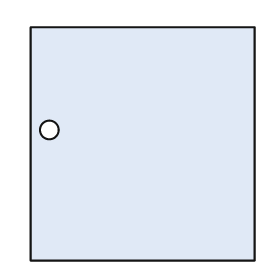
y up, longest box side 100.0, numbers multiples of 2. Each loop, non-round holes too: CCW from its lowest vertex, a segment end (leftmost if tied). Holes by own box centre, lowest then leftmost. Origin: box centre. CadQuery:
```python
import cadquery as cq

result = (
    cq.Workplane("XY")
    .moveTo(-48.0, -50.0)
    .lineTo(48.0, -50.0)
    .lineTo(48.0, 50.0)
    .lineTo(-48.0, 50.0)
    .close()
    .moveTo(-40.0, 6.0)
    .circle(4.0)
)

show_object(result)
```